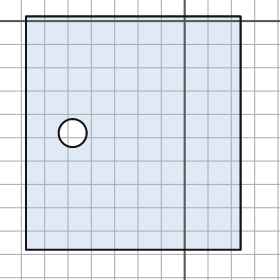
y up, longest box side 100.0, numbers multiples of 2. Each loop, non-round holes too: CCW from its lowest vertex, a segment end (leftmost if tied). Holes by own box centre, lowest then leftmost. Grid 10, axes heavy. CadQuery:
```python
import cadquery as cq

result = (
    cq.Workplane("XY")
    .moveTo(-68.0, -98.0)
    .lineTo(24.0, -98.0)
    .lineTo(24.0, 2.0)
    .lineTo(-68.0, 2.0)
    .close()
    .moveTo(-48.0, -48.0)
    .circle(6.0)
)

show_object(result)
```